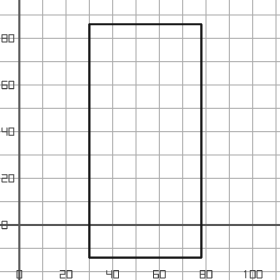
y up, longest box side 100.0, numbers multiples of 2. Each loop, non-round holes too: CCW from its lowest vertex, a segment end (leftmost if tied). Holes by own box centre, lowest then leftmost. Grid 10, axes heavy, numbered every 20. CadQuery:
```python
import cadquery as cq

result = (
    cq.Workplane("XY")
    .moveTo(30.0, -14.0)
    .lineTo(78.0, -14.0)
    .lineTo(78.0, 86.0)
    .lineTo(30.0, 86.0)
    .close()
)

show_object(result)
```